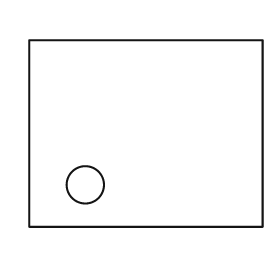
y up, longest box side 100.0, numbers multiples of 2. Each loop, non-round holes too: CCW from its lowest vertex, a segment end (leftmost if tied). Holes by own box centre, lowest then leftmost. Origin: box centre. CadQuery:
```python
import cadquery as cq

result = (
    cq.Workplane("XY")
    .moveTo(-50.0, -40.0)
    .lineTo(50.0, -40.0)
    .lineTo(50.0, 40.0)
    .lineTo(-50.0, 40.0)
    .close()
    .moveTo(-26.0, -22.0)
    .circle(8.0)
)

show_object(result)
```